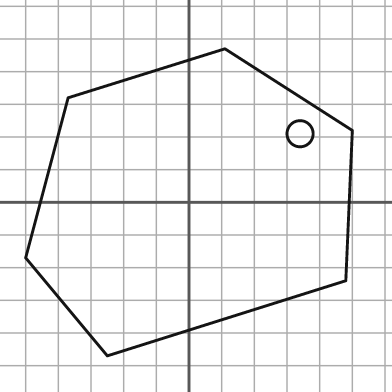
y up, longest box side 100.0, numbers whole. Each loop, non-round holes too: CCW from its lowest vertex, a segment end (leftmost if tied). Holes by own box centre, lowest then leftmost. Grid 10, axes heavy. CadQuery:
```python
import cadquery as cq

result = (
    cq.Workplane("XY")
    .moveTo(-25.0, -47.0)
    .lineTo(48.0, -24.0)
    .lineTo(50.0, 22.0)
    .lineTo(11.0, 47.0)
    .lineTo(-37.0, 32.0)
    .lineTo(-50.0, -17.0)
    .close()
    .moveTo(34.0, 21.0)
    .circle(4.0)
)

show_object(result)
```